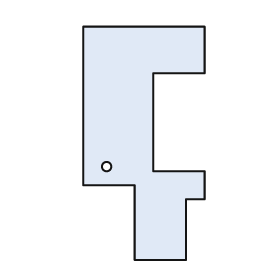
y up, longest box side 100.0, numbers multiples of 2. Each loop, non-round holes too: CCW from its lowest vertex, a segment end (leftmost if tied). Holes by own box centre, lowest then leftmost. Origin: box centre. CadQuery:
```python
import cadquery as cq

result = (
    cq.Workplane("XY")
    .moveTo(-4.0, -50.0)
    .lineTo(18.0, -50.0)
    .lineTo(18.0, -24.0)
    .lineTo(26.0, -24.0)
    .lineTo(26.0, -12.0)
    .lineTo(4.0, -12.0)
    .lineTo(4.0, 30.0)
    .lineTo(26.0, 30.0)
    .lineTo(26.0, 50.0)
    .lineTo(-26.0, 50.0)
    .lineTo(-26.0, -18.0)
    .lineTo(-4.0, -18.0)
    .close()
    .moveTo(-16.0, -10.0)
    .circle(2.0)
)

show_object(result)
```